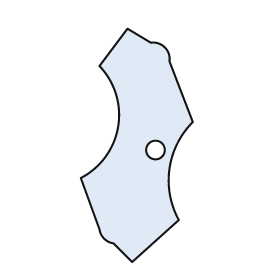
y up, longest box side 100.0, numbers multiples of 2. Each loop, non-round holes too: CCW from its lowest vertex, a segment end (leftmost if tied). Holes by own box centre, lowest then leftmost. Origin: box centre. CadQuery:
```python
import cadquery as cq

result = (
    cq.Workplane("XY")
    .moveTo(-2.0, -50.0)
    .lineTo(18.0, -32.0)
    .threePointArc((14.0, -10.0), (24.0, 10.0))
    .lineTo(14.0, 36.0)
    .threePointArc((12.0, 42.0), (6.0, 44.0))
    .lineTo(-4.0, 50.0)
    .lineTo(-16.0, 34.0)
    .threePointArc((-8.0, 8.0), (-24.0, -14.0))
    .lineTo(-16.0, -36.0)
    .threePointArc((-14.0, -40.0), (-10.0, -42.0))
    .close()
    .moveTo(8.0, -2.0)
    .circle(4.0)
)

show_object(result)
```